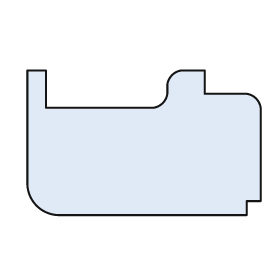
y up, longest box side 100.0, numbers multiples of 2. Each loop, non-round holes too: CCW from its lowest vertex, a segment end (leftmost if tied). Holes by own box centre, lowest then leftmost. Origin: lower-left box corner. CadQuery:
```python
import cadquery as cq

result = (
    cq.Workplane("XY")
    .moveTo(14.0, 0.0)
    .lineTo(94.0, 0.0)
    .lineTo(94.0, 6.0)
    .lineTo(100.0, 6.0)
    .lineTo(100.0, 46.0)
    .threePointArc((98.0, 50.0), (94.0, 52.0))
    .lineTo(76.0, 52.0)
    .lineTo(76.0, 62.0)
    .lineTo(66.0, 62.0)
    .threePointArc((62.0, 60.0), (60.0, 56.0))
    .lineTo(60.0, 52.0)
    .threePointArc((58.0, 48.0), (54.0, 46.0))
    .lineTo(8.0, 46.0)
    .lineTo(8.0, 62.0)
    .lineTo(0.0, 62.0)
    .lineTo(0.0, 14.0)
    .threePointArc((4.0, 4.0), (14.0, 0.0))
    .close()
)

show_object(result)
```